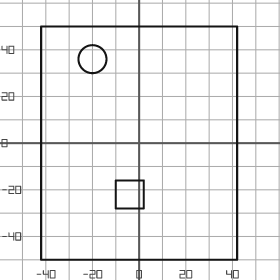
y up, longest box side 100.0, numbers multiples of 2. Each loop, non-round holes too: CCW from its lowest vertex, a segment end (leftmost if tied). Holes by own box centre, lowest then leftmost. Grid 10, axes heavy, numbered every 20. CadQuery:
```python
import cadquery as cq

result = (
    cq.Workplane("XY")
    .moveTo(-42.0, -50.0)
    .lineTo(42.0, -50.0)
    .lineTo(42.0, 50.0)
    .lineTo(-42.0, 50.0)
    .close()
    .moveTo(-10.0, -28.0)
    .lineTo(2.0, -28.0)
    .lineTo(2.0, -16.0)
    .lineTo(-10.0, -16.0)
    .close()
    .moveTo(-20.0, 36.0)
    .circle(6.0)
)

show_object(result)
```